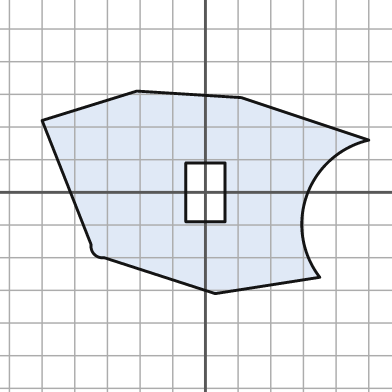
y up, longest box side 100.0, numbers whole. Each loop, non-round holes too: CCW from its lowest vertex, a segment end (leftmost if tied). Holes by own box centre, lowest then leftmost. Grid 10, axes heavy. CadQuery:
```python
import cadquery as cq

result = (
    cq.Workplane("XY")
    .moveTo(3.0, -31.0)
    .lineTo(35.0, -26.0)
    .threePointArc((31.0, -1.0), (50.0, 16.0))
    .lineTo(11.0, 29.0)
    .lineTo(-21.0, 31.0)
    .lineTo(-50.0, 22.0)
    .lineTo(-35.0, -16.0)
    .threePointArc((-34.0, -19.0), (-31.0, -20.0))
    .close()
    .moveTo(-6.0, -9.0)
    .lineTo(6.0, -9.0)
    .lineTo(6.0, 9.0)
    .lineTo(-6.0, 9.0)
    .close()
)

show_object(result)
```